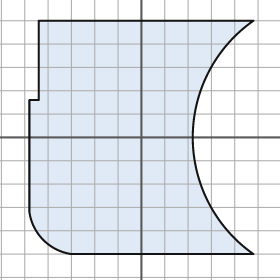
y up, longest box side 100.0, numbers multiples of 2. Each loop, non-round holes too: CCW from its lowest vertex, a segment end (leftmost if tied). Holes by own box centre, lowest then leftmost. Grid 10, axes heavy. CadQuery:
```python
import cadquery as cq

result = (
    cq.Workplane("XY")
    .moveTo(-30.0, -50.0)
    .lineTo(48.0, -50.0)
    .threePointArc((22.0, 0.0), (48.0, 50.0))
    .lineTo(-44.0, 50.0)
    .lineTo(-44.0, 16.0)
    .lineTo(-48.0, 16.0)
    .lineTo(-48.0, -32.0)
    .threePointArc((-42.0, -44.0), (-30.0, -50.0))
    .close()
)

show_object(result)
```